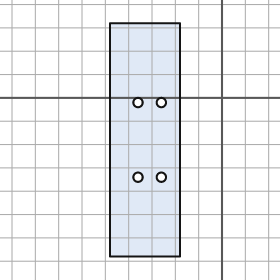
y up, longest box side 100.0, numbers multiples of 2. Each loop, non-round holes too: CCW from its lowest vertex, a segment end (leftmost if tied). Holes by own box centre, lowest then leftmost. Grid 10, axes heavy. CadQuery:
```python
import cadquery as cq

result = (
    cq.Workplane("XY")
    .moveTo(-48.0, -68.0)
    .lineTo(-18.0, -68.0)
    .lineTo(-18.0, 32.0)
    .lineTo(-48.0, 32.0)
    .close()
    .moveTo(-36.0, -34.0)
    .circle(2.0)
    .moveTo(-26.0, -34.0)
    .circle(2.0)
    .moveTo(-36.0, -2.0)
    .circle(2.0)
    .moveTo(-26.0, -2.0)
    .circle(2.0)
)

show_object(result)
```